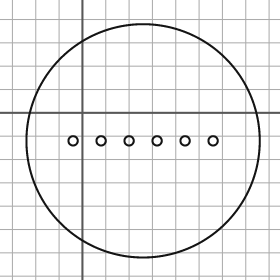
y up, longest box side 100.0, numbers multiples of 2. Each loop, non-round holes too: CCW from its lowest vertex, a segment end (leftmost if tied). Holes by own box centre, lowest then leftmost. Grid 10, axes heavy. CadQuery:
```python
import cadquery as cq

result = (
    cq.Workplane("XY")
    .moveTo(26.0, -12.0)
    .circle(50.0)
    .moveTo(-4.0, -12.0)
    .circle(2.0)
    .moveTo(8.0, -12.0)
    .circle(2.0)
    .moveTo(20.0, -12.0)
    .circle(2.0)
    .moveTo(32.0, -12.0)
    .circle(2.0)
    .moveTo(44.0, -12.0)
    .circle(2.0)
    .moveTo(56.0, -12.0)
    .circle(2.0)
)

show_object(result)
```